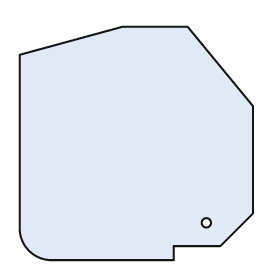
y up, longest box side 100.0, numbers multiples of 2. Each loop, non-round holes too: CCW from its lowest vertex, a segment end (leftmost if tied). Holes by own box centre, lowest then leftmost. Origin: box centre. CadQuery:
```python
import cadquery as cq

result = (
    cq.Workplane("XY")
    .moveTo(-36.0, -50.0)
    .lineTo(16.0, -50.0)
    .lineTo(16.0, -44.0)
    .lineTo(36.0, -44.0)
    .lineTo(50.0, -30.0)
    .lineTo(50.0, 16.0)
    .lineTo(22.0, 50.0)
    .lineTo(-6.0, 50.0)
    .lineTo(-50.0, 38.0)
    .lineTo(-50.0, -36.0)
    .threePointArc((-46.0, -46.0), (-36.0, -50.0))
    .close()
    .moveTo(30.0, -34.0)
    .circle(2.0)
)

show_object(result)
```